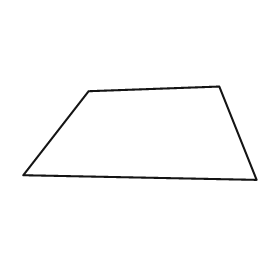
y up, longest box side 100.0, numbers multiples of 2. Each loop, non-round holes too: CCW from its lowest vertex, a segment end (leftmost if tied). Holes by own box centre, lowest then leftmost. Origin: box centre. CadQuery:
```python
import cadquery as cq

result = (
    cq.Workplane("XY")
    .moveTo(50.0, -20.0)
    .lineTo(34.0, 20.0)
    .lineTo(-22.0, 18.0)
    .lineTo(-50.0, -18.0)
    .close()
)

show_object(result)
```